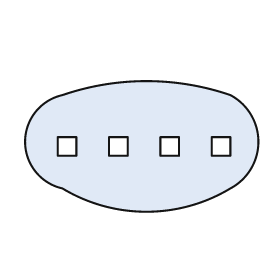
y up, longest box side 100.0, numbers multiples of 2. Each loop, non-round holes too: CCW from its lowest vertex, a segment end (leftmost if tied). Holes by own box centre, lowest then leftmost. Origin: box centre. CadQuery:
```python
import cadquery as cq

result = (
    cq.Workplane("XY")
    .moveTo(-34.0, -18.0)
    .threePointArc((2.0, -28.0), (38.0, -18.0))
    .threePointArc((50.0, 2.0), (38.0, 22.0))
    .threePointArc((2.0, 28.0), (-34.0, 22.0))
    .threePointArc((-50.0, 2.0), (-34.0, -18.0))
    .close()
    .moveTo(-36.0, -4.0)
    .lineTo(-28.0, -4.0)
    .lineTo(-28.0, 4.0)
    .lineTo(-36.0, 4.0)
    .close()
    .moveTo(-14.0, -4.0)
    .lineTo(-6.0, -4.0)
    .lineTo(-6.0, 4.0)
    .lineTo(-14.0, 4.0)
    .close()
    .moveTo(8.0, -4.0)
    .lineTo(16.0, -4.0)
    .lineTo(16.0, 4.0)
    .lineTo(8.0, 4.0)
    .close()
    .moveTo(30.0, -4.0)
    .lineTo(38.0, -4.0)
    .lineTo(38.0, 4.0)
    .lineTo(30.0, 4.0)
    .close()
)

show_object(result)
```